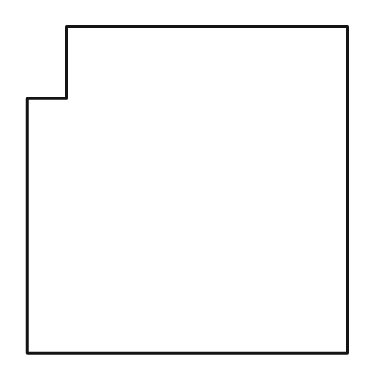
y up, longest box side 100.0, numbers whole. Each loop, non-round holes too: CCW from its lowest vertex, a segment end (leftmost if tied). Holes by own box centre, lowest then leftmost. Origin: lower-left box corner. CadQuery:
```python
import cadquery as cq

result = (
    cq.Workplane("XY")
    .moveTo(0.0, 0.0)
    .lineTo(98.0, 0.0)
    .lineTo(98.0, 100.0)
    .lineTo(12.0, 100.0)
    .lineTo(12.0, 78.0)
    .lineTo(0.0, 78.0)
    .close()
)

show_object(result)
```